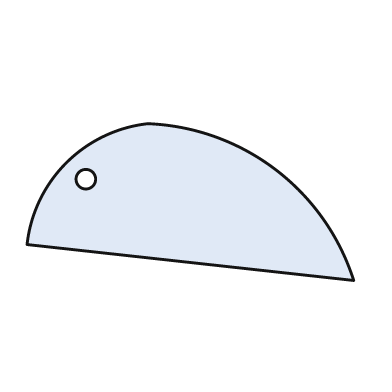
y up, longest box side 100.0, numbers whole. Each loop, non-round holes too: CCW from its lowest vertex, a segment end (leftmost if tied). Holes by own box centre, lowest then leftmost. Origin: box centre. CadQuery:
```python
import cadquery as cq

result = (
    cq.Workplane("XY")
    .moveTo(50.0, -24.0)
    .threePointArc((26.0, 10.0), (-13.0, 24.0))
    .threePointArc((-38.0, 12.0), (-50.0, -13.0))
    .close()
    .moveTo(-32.0, 7.0)
    .circle(3.0)
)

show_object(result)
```